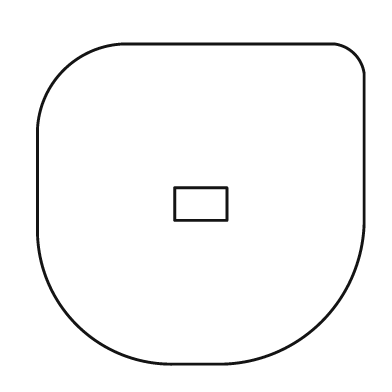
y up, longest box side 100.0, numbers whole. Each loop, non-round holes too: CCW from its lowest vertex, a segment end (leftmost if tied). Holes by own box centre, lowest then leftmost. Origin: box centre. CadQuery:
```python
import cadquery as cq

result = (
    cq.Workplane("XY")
    .moveTo(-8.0, -49.0)
    .lineTo(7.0, -49.0)
    .threePointArc((37.0, -36.0), (50.0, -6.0))
    .lineTo(50.0, 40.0)
    .threePointArc((47.0, 46.0), (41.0, 49.0))
    .lineTo(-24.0, 49.0)
    .threePointArc((-42.0, 41.0), (-50.0, 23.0))
    .lineTo(-50.0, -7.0)
    .threePointArc((-38.0, -37.0), (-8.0, -49.0))
    .close()
    .moveTo(-8.0, -5.0)
    .lineTo(8.0, -5.0)
    .lineTo(8.0, 5.0)
    .lineTo(-8.0, 5.0)
    .close()
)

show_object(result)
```